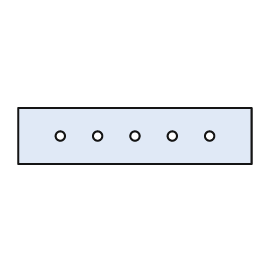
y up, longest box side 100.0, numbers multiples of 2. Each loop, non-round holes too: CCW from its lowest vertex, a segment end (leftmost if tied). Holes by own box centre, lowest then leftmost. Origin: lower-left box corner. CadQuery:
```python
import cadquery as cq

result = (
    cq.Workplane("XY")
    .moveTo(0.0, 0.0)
    .lineTo(100.0, 0.0)
    .lineTo(100.0, 24.0)
    .lineTo(0.0, 24.0)
    .close()
    .moveTo(18.0, 12.0)
    .circle(2.0)
    .moveTo(34.0, 12.0)
    .circle(2.0)
    .moveTo(50.0, 12.0)
    .circle(2.0)
    .moveTo(66.0, 12.0)
    .circle(2.0)
    .moveTo(82.0, 12.0)
    .circle(2.0)
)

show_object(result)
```